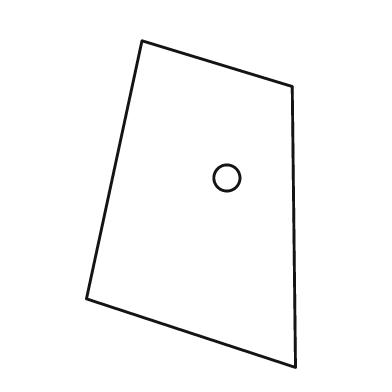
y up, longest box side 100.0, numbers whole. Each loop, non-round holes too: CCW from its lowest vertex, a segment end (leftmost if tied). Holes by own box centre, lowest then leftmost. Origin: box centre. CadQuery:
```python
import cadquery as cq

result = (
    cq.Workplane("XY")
    .moveTo(32.0, -50.0)
    .lineTo(31.0, 36.0)
    .lineTo(-15.0, 50.0)
    .lineTo(-32.0, -29.0)
    .close()
    .moveTo(11.0, 8.0)
    .circle(4.0)
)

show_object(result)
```